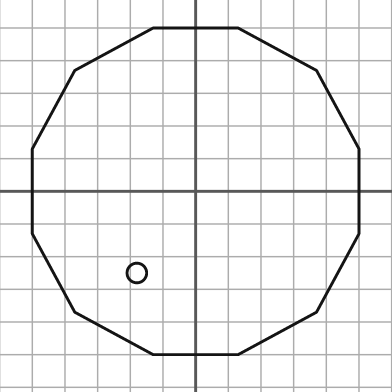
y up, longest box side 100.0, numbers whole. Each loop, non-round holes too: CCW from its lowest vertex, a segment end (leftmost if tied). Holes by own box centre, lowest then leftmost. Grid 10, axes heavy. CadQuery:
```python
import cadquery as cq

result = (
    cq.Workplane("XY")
    .moveTo(-13.0, -50.0)
    .lineTo(13.0, -50.0)
    .lineTo(37.0, -37.0)
    .lineTo(50.0, -13.0)
    .lineTo(50.0, 13.0)
    .lineTo(37.0, 37.0)
    .lineTo(13.0, 50.0)
    .lineTo(-13.0, 50.0)
    .lineTo(-37.0, 37.0)
    .lineTo(-50.0, 13.0)
    .lineTo(-50.0, -13.0)
    .lineTo(-37.0, -37.0)
    .close()
    .moveTo(-18.0, -25.0)
    .circle(3.0)
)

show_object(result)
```